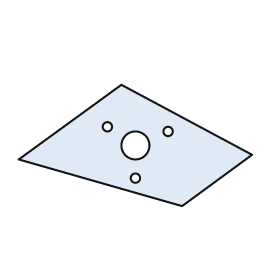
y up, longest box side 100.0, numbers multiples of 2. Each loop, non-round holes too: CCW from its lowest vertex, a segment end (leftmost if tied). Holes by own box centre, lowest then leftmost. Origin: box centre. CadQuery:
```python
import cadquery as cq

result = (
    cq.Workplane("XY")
    .moveTo(20.0, -26.0)
    .lineTo(50.0, -4.0)
    .lineTo(-6.0, 26.0)
    .lineTo(-50.0, -6.0)
    .close()
    .moveTo(0.0, -14.0)
    .circle(2.0)
    .moveTo(0.0, 0.0)
    .circle(6.0)
    .moveTo(14.0, 6.0)
    .circle(2.0)
    .moveTo(-12.0, 8.0)
    .circle(2.0)
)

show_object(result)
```